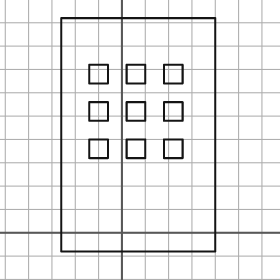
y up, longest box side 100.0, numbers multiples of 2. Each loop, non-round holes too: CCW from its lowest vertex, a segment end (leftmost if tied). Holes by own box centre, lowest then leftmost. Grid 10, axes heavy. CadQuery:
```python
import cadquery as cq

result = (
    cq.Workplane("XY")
    .moveTo(-26.0, -8.0)
    .lineTo(40.0, -8.0)
    .lineTo(40.0, 92.0)
    .lineTo(-26.0, 92.0)
    .close()
    .moveTo(-14.0, 32.0)
    .lineTo(-6.0, 32.0)
    .lineTo(-6.0, 40.0)
    .lineTo(-14.0, 40.0)
    .close()
    .moveTo(2.0, 32.0)
    .lineTo(10.0, 32.0)
    .lineTo(10.0, 40.0)
    .lineTo(2.0, 40.0)
    .close()
    .moveTo(18.0, 32.0)
    .lineTo(26.0, 32.0)
    .lineTo(26.0, 40.0)
    .lineTo(18.0, 40.0)
    .close()
    .moveTo(-14.0, 48.0)
    .lineTo(-6.0, 48.0)
    .lineTo(-6.0, 56.0)
    .lineTo(-14.0, 56.0)
    .close()
    .moveTo(2.0, 48.0)
    .lineTo(10.0, 48.0)
    .lineTo(10.0, 56.0)
    .lineTo(2.0, 56.0)
    .close()
    .moveTo(18.0, 48.0)
    .lineTo(26.0, 48.0)
    .lineTo(26.0, 56.0)
    .lineTo(18.0, 56.0)
    .close()
    .moveTo(-14.0, 64.0)
    .lineTo(-6.0, 64.0)
    .lineTo(-6.0, 72.0)
    .lineTo(-14.0, 72.0)
    .close()
    .moveTo(2.0, 64.0)
    .lineTo(10.0, 64.0)
    .lineTo(10.0, 72.0)
    .lineTo(2.0, 72.0)
    .close()
    .moveTo(18.0, 64.0)
    .lineTo(26.0, 64.0)
    .lineTo(26.0, 72.0)
    .lineTo(18.0, 72.0)
    .close()
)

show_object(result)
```